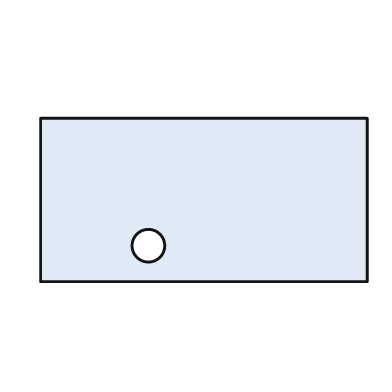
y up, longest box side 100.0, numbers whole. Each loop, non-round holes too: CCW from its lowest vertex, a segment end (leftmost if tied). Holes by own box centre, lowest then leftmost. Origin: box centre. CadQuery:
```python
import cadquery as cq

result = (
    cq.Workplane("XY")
    .moveTo(-50.0, -25.0)
    .lineTo(50.0, -25.0)
    .lineTo(50.0, 25.0)
    .lineTo(-50.0, 25.0)
    .close()
    .moveTo(-17.0, -14.0)
    .circle(5.0)
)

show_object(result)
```